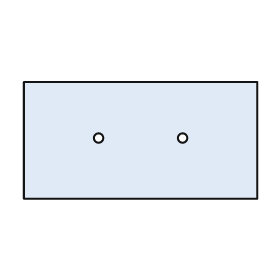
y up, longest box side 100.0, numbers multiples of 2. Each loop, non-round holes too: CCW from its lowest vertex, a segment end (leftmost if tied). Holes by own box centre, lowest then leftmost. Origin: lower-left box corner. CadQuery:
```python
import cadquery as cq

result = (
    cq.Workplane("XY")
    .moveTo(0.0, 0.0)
    .lineTo(100.0, 0.0)
    .lineTo(100.0, 50.0)
    .lineTo(0.0, 50.0)
    .close()
    .moveTo(32.0, 26.0)
    .circle(2.0)
    .moveTo(68.0, 26.0)
    .circle(2.0)
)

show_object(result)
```